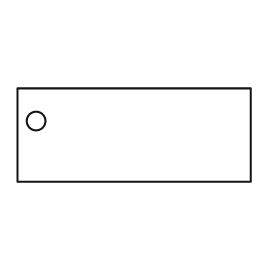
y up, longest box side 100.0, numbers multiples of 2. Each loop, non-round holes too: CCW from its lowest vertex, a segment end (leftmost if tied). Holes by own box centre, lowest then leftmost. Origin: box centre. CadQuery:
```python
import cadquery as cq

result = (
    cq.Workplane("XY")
    .moveTo(-50.0, -20.0)
    .lineTo(50.0, -20.0)
    .lineTo(50.0, 20.0)
    .lineTo(-50.0, 20.0)
    .close()
    .moveTo(-42.0, 6.0)
    .circle(4.0)
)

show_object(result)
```